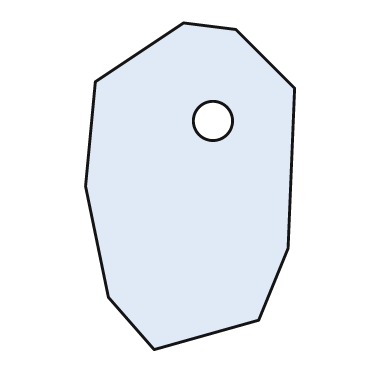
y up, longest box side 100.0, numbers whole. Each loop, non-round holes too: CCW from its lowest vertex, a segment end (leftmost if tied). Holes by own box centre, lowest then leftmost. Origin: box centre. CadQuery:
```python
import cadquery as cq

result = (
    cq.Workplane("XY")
    .moveTo(-11.0, -50.0)
    .lineTo(21.0, -41.0)
    .lineTo(30.0, -19.0)
    .lineTo(32.0, 30.0)
    .lineTo(14.0, 48.0)
    .lineTo(-2.0, 50.0)
    .lineTo(-29.0, 32.0)
    .lineTo(-32.0, 0.0)
    .lineTo(-25.0, -34.0)
    .close()
    .moveTo(7.0, 20.0)
    .circle(6.0)
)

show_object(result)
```